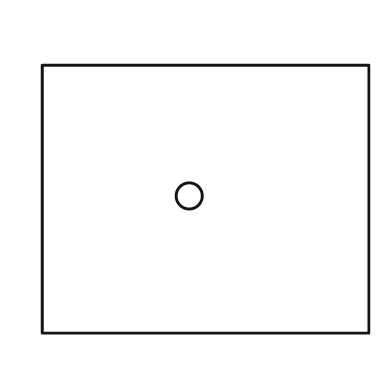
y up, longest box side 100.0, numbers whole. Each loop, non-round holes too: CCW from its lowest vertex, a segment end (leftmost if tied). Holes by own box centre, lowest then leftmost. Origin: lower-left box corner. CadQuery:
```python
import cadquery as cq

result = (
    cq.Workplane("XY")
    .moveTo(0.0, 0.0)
    .lineTo(100.0, 0.0)
    .lineTo(100.0, 82.0)
    .lineTo(0.0, 82.0)
    .close()
    .moveTo(45.0, 42.0)
    .circle(4.0)
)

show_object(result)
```